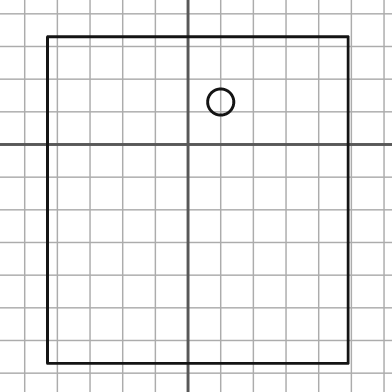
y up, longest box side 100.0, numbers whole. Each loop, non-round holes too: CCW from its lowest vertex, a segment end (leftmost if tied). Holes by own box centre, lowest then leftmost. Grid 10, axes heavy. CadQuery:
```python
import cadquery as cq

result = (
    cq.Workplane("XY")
    .moveTo(-43.0, -67.0)
    .lineTo(49.0, -67.0)
    .lineTo(49.0, 33.0)
    .lineTo(-43.0, 33.0)
    .close()
    .moveTo(10.0, 13.0)
    .circle(4.0)
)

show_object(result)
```